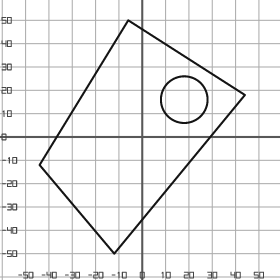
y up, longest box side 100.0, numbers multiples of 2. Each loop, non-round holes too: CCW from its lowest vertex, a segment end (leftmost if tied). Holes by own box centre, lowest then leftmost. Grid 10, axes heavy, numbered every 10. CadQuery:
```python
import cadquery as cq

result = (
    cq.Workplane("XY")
    .moveTo(-12.0, -50.0)
    .lineTo(44.0, 18.0)
    .lineTo(-6.0, 50.0)
    .lineTo(-44.0, -12.0)
    .close()
    .moveTo(18.0, 16.0)
    .circle(10.0)
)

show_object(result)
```